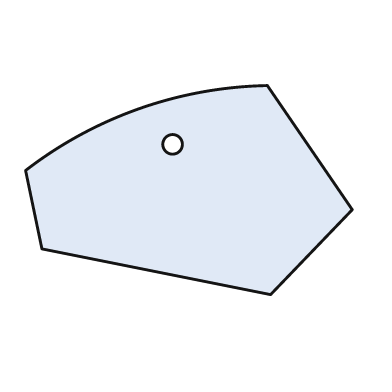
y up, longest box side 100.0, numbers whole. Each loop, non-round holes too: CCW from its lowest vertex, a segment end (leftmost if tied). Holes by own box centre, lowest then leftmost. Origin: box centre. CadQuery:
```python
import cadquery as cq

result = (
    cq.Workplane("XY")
    .moveTo(25.0, -32.0)
    .lineTo(50.0, -6.0)
    .lineTo(24.0, 32.0)
    .threePointArc((-15.0, 25.0), (-50.0, 6.0))
    .lineTo(-45.0, -18.0)
    .close()
    .moveTo(-5.0, 14.0)
    .circle(3.0)
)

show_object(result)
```